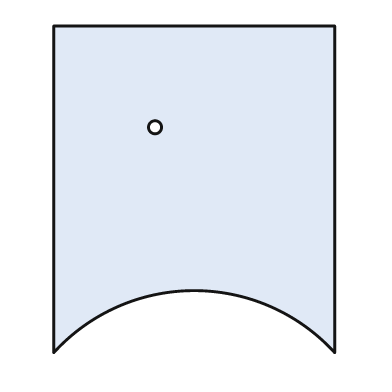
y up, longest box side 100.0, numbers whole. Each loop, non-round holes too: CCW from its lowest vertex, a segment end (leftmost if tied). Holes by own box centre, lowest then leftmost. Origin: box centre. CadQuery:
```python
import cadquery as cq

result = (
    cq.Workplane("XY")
    .moveTo(-43.0, -50.0)
    .threePointArc((0.0, -31.0), (43.0, -50.0))
    .lineTo(43.0, 50.0)
    .lineTo(-43.0, 50.0)
    .close()
    .moveTo(-12.0, 19.0)
    .circle(2.0)
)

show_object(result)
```